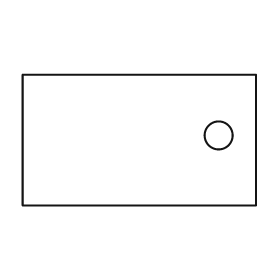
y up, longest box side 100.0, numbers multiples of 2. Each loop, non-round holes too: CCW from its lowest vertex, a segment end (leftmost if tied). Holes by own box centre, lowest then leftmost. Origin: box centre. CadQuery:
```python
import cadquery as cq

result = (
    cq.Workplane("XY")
    .moveTo(-50.0, -28.0)
    .lineTo(50.0, -28.0)
    .lineTo(50.0, 28.0)
    .lineTo(-50.0, 28.0)
    .close()
    .moveTo(34.0, 2.0)
    .circle(6.0)
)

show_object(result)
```